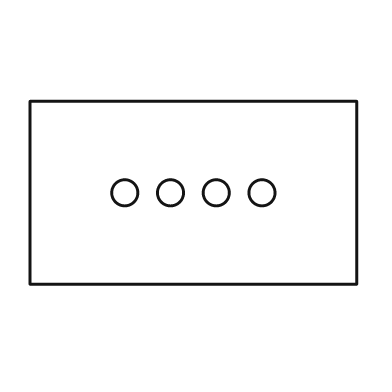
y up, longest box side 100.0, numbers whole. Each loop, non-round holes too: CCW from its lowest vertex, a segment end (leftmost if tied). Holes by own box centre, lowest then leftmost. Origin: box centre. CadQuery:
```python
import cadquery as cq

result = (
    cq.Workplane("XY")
    .moveTo(-50.0, -28.0)
    .lineTo(50.0, -28.0)
    .lineTo(50.0, 28.0)
    .lineTo(-50.0, 28.0)
    .close()
    .moveTo(-21.0, 0.0)
    .circle(4.0)
    .moveTo(-7.0, 0.0)
    .circle(4.0)
    .moveTo(7.0, 0.0)
    .circle(4.0)
    .moveTo(21.0, 0.0)
    .circle(4.0)
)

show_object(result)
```